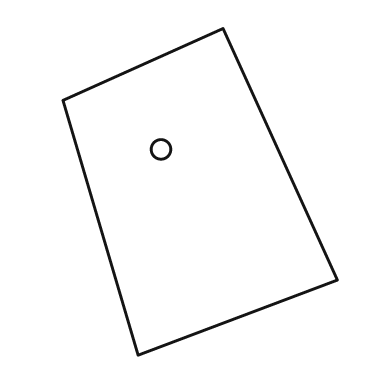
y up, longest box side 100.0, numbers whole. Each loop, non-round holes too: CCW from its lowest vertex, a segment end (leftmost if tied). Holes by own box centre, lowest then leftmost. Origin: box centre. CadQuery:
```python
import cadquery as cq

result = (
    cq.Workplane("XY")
    .moveTo(-19.0, -50.0)
    .lineTo(42.0, -27.0)
    .lineTo(7.0, 50.0)
    .lineTo(-42.0, 28.0)
    .close()
    .moveTo(-12.0, 13.0)
    .circle(3.0)
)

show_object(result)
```